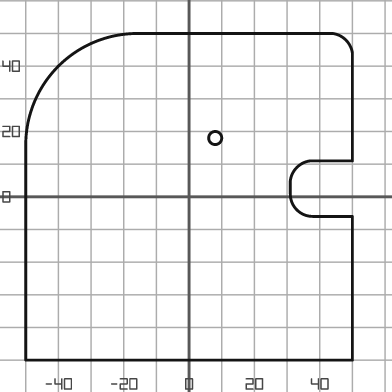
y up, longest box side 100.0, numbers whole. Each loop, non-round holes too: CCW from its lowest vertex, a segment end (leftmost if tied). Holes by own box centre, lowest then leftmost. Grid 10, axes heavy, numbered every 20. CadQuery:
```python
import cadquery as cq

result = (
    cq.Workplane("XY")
    .moveTo(-50.0, -50.0)
    .lineTo(50.0, -50.0)
    .lineTo(50.0, -6.0)
    .lineTo(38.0, -6.0)
    .threePointArc((33.0, -4.0), (31.0, 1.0))
    .lineTo(31.0, 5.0)
    .threePointArc((33.0, 9.0), (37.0, 11.0))
    .lineTo(50.0, 11.0)
    .lineTo(50.0, 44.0)
    .threePointArc((48.0, 48.0), (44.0, 50.0))
    .lineTo(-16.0, 50.0)
    .threePointArc((-40.0, 40.0), (-50.0, 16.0))
    .close()
    .moveTo(8.0, 18.0)
    .circle(2.0)
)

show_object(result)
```